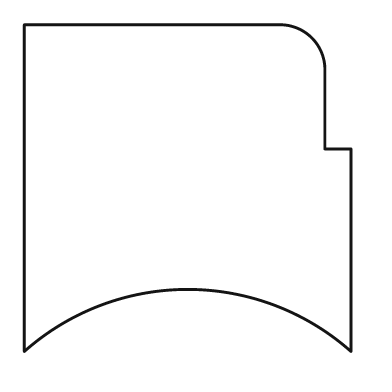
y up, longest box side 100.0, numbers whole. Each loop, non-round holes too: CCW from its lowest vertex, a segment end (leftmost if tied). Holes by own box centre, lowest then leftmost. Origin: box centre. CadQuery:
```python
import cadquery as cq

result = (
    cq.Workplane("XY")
    .moveTo(-50.0, -50.0)
    .threePointArc((0.0, -31.0), (50.0, -50.0))
    .lineTo(50.0, 12.0)
    .lineTo(42.0, 12.0)
    .lineTo(42.0, 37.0)
    .threePointArc((38.0, 46.0), (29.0, 50.0))
    .lineTo(-50.0, 50.0)
    .close()
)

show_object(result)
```